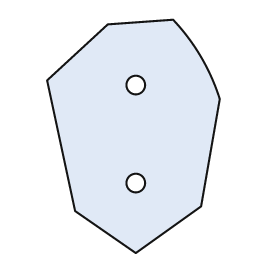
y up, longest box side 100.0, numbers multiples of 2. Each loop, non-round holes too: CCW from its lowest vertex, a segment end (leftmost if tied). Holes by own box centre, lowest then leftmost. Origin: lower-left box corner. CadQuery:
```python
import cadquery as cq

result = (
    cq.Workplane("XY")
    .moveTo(38.0, 0.0)
    .lineTo(66.0, 20.0)
    .lineTo(74.0, 66.0)
    .threePointArc((66.0, 84.0), (54.0, 100.0))
    .lineTo(26.0, 98.0)
    .lineTo(0.0, 74.0)
    .lineTo(12.0, 18.0)
    .close()
    .moveTo(38.0, 30.0)
    .circle(4.0)
    .moveTo(38.0, 72.0)
    .circle(4.0)
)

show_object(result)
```